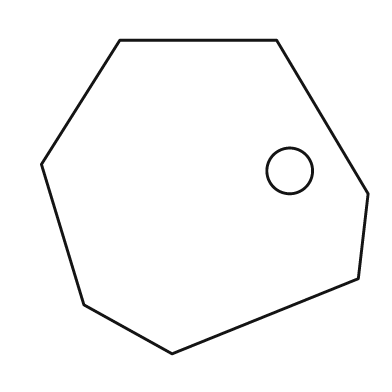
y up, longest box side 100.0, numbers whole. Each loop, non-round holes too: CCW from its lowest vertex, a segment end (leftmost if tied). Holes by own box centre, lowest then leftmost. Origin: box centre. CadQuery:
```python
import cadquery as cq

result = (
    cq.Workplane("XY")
    .moveTo(-10.0, -48.0)
    .lineTo(47.0, -25.0)
    .lineTo(50.0, 1.0)
    .lineTo(22.0, 48.0)
    .lineTo(-26.0, 48.0)
    .lineTo(-50.0, 10.0)
    .lineTo(-37.0, -33.0)
    .close()
    .moveTo(26.0, 8.0)
    .circle(7.0)
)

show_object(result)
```